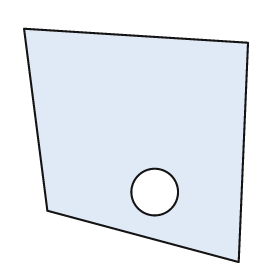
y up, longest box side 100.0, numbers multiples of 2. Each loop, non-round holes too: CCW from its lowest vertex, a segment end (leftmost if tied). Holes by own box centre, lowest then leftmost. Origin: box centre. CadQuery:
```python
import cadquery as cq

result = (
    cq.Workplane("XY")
    .moveTo(44.0, -50.0)
    .lineTo(48.0, 44.0)
    .lineTo(-48.0, 50.0)
    .lineTo(-38.0, -28.0)
    .close()
    .moveTo(8.0, -20.0)
    .circle(10.0)
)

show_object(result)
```